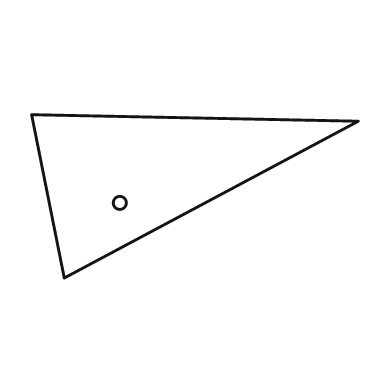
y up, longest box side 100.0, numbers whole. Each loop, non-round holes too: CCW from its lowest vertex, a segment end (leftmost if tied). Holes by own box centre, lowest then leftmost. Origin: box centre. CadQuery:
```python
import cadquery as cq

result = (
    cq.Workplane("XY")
    .moveTo(-40.0, -25.0)
    .lineTo(50.0, 23.0)
    .lineTo(-50.0, 25.0)
    .close()
    .moveTo(-23.0, -2.0)
    .circle(2.0)
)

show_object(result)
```